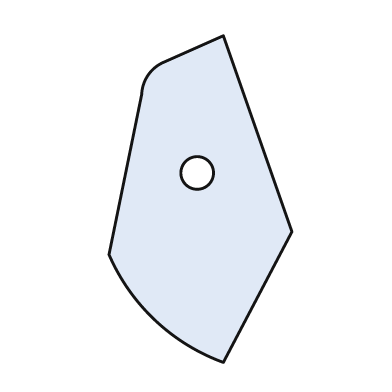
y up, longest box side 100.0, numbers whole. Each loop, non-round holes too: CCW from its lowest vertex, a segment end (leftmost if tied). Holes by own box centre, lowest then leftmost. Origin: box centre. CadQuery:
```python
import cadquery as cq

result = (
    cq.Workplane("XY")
    .moveTo(7.0, -50.0)
    .lineTo(28.0, -10.0)
    .lineTo(7.0, 50.0)
    .lineTo(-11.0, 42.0)
    .threePointArc((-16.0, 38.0), (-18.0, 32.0))
    .lineTo(-28.0, -17.0)
    .threePointArc((-14.0, -37.0), (7.0, -50.0))
    .close()
    .moveTo(-1.0, 8.0)
    .circle(5.0)
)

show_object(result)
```